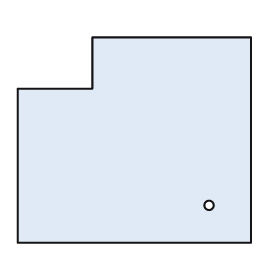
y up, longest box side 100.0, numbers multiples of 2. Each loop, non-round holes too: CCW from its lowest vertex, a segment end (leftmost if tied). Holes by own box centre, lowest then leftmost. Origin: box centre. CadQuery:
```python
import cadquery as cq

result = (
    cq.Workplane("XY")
    .moveTo(-50.0, -44.0)
    .lineTo(50.0, -44.0)
    .lineTo(50.0, 44.0)
    .lineTo(-18.0, 44.0)
    .lineTo(-18.0, 22.0)
    .lineTo(-50.0, 22.0)
    .close()
    .moveTo(32.0, -28.0)
    .circle(2.0)
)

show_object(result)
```